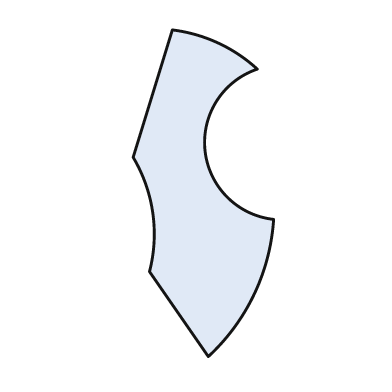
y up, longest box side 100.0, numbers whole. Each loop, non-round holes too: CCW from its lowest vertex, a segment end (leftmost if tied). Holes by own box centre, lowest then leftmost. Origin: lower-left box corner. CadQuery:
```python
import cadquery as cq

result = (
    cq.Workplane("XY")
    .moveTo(23.0, 0.0)
    .threePointArc((37.0, 19.0), (43.0, 42.0))
    .threePointArc((22.0, 63.0), (38.0, 88.0))
    .threePointArc((26.0, 96.0), (12.0, 100.0))
    .lineTo(0.0, 61.0)
    .threePointArc((6.0, 44.0), (5.0, 26.0))
    .close()
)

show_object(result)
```